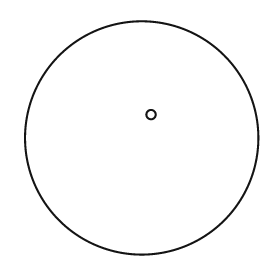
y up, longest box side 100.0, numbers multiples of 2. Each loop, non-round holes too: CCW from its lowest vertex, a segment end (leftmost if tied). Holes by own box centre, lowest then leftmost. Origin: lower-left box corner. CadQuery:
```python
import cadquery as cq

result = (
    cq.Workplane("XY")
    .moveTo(50.0, 50.0)
    .circle(50.0)
    .moveTo(54.0, 60.0)
    .circle(2.0)
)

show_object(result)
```